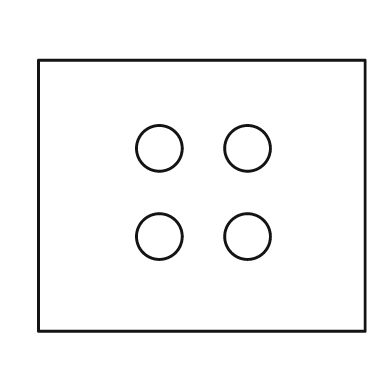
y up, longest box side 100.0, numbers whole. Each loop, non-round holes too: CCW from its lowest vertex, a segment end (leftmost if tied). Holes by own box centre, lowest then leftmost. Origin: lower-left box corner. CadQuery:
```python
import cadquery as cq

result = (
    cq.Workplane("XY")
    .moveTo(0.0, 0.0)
    .lineTo(100.0, 0.0)
    .lineTo(100.0, 83.0)
    .lineTo(0.0, 83.0)
    .close()
    .moveTo(37.0, 29.0)
    .circle(7.0)
    .moveTo(64.0, 29.0)
    .circle(7.0)
    .moveTo(37.0, 56.0)
    .circle(7.0)
    .moveTo(64.0, 56.0)
    .circle(7.0)
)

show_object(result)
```